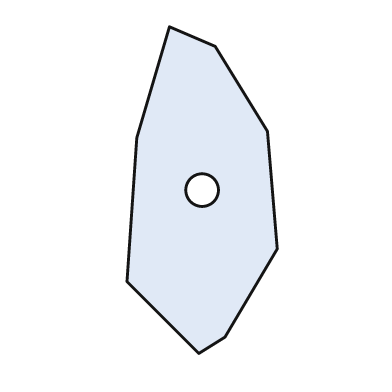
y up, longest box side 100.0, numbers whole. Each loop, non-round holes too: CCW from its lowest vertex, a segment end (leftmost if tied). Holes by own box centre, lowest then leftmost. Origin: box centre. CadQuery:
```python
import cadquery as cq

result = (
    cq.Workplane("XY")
    .moveTo(-1.0, -50.0)
    .lineTo(7.0, -45.0)
    .lineTo(23.0, -18.0)
    .lineTo(20.0, 18.0)
    .lineTo(4.0, 44.0)
    .lineTo(-10.0, 50.0)
    .lineTo(-20.0, 16.0)
    .lineTo(-23.0, -28.0)
    .close()
    .moveTo(0.0, 0.0)
    .circle(5.0)
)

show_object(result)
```